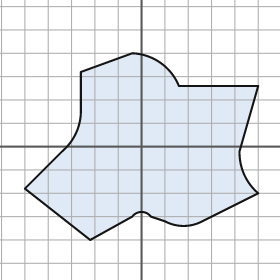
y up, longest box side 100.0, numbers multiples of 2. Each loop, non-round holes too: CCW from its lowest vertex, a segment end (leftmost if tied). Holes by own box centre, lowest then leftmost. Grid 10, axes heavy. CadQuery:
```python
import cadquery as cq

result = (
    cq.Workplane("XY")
    .moveTo(-22.0, -40.0)
    .lineTo(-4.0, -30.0)
    .threePointArc((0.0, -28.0), (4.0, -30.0))
    .lineTo(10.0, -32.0)
    .threePointArc((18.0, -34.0), (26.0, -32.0))
    .lineTo(50.0, -20.0)
    .threePointArc((44.0, -12.0), (42.0, -2.0))
    .lineTo(50.0, 26.0)
    .lineTo(16.0, 26.0)
    .threePointArc((8.0, 36.0), (-4.0, 40.0))
    .lineTo(-26.0, 32.0)
    .lineTo(-26.0, 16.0)
    .threePointArc((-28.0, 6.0), (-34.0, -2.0))
    .lineTo(-50.0, -18.0)
    .close()
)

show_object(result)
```